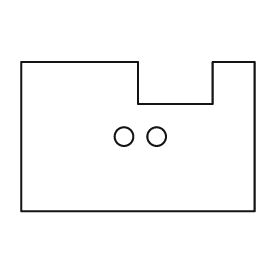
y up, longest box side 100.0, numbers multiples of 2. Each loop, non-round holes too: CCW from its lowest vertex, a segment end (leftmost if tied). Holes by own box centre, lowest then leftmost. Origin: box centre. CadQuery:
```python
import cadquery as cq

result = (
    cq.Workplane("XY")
    .moveTo(-50.0, -32.0)
    .lineTo(50.0, -32.0)
    .lineTo(50.0, 32.0)
    .lineTo(32.0, 32.0)
    .lineTo(32.0, 14.0)
    .lineTo(0.0, 14.0)
    .lineTo(0.0, 32.0)
    .lineTo(-50.0, 32.0)
    .close()
    .moveTo(-6.0, 0.0)
    .circle(4.0)
    .moveTo(8.0, 0.0)
    .circle(4.0)
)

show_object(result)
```